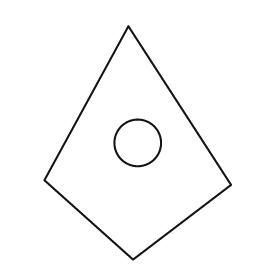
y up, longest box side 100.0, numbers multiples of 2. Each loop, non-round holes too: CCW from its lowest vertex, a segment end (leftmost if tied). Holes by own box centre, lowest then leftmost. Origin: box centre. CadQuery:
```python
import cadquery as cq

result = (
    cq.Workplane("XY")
    .moveTo(-2.0, -50.0)
    .lineTo(40.0, -18.0)
    .lineTo(-4.0, 50.0)
    .lineTo(-40.0, -16.0)
    .close()
    .moveTo(0.0, 0.0)
    .circle(10.0)
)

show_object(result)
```